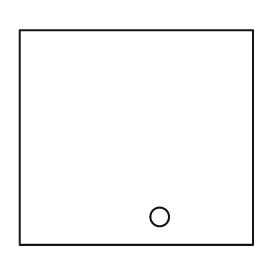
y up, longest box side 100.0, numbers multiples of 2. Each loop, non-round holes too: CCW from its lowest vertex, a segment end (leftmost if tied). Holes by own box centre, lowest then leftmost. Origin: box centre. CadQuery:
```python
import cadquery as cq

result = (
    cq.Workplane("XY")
    .moveTo(-50.0, -46.0)
    .lineTo(50.0, -46.0)
    .lineTo(50.0, 46.0)
    .lineTo(-50.0, 46.0)
    .close()
    .moveTo(10.0, -34.0)
    .circle(4.0)
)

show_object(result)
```